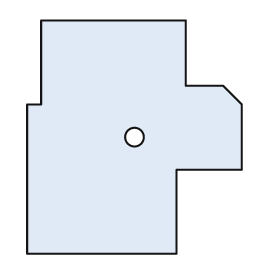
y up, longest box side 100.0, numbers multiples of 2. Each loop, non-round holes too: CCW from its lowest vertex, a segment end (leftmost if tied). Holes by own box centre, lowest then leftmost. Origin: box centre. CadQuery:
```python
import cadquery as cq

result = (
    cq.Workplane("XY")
    .moveTo(-46.0, -50.0)
    .lineTo(18.0, -50.0)
    .lineTo(18.0, -14.0)
    .lineTo(46.0, -14.0)
    .lineTo(46.0, 14.0)
    .lineTo(38.0, 22.0)
    .lineTo(22.0, 22.0)
    .lineTo(22.0, 50.0)
    .lineTo(-40.0, 50.0)
    .lineTo(-40.0, 14.0)
    .lineTo(-46.0, 14.0)
    .close()
    .moveTo(0.0, 0.0)
    .circle(4.0)
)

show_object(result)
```